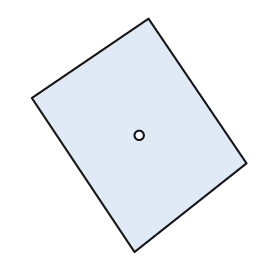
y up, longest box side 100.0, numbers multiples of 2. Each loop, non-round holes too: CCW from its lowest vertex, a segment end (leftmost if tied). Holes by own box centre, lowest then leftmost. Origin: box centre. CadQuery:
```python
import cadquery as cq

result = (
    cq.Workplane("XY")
    .moveTo(-2.0, -50.0)
    .lineTo(46.0, -12.0)
    .lineTo(4.0, 50.0)
    .lineTo(-46.0, 16.0)
    .close()
    .moveTo(0.0, 0.0)
    .circle(2.0)
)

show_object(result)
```